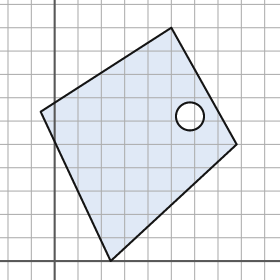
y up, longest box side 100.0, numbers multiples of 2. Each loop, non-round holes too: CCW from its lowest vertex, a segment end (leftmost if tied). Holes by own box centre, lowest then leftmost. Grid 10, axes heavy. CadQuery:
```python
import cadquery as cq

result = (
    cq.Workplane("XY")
    .moveTo(24.0, 0.0)
    .lineTo(78.0, 50.0)
    .lineTo(50.0, 100.0)
    .lineTo(-6.0, 64.0)
    .close()
    .moveTo(58.0, 62.0)
    .circle(6.0)
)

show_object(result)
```